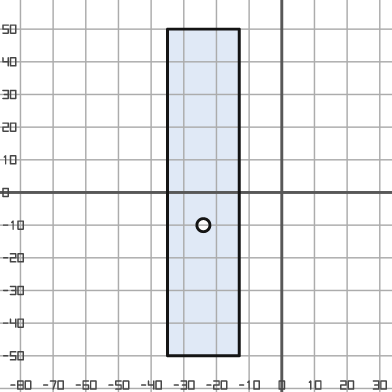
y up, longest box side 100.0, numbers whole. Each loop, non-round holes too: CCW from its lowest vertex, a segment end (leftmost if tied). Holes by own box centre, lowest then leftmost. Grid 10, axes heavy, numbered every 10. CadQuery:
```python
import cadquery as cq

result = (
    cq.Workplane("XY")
    .moveTo(-35.0, -50.0)
    .lineTo(-13.0, -50.0)
    .lineTo(-13.0, 50.0)
    .lineTo(-35.0, 50.0)
    .close()
    .moveTo(-24.0, -10.0)
    .circle(2.0)
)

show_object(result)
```